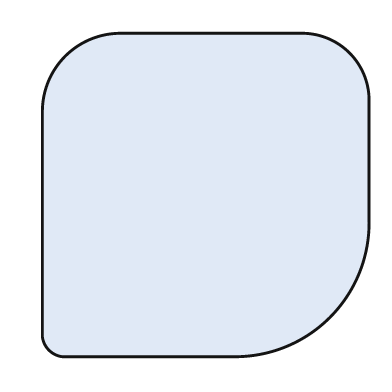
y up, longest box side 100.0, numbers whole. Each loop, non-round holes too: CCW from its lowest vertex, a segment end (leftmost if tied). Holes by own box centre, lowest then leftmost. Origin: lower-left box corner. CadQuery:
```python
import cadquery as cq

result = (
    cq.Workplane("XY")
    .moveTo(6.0, 0.0)
    .lineTo(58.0, 0.0)
    .threePointArc((88.0, 12.0), (100.0, 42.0))
    .lineTo(100.0, 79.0)
    .threePointArc((94.0, 93.0), (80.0, 99.0))
    .lineTo(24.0, 99.0)
    .threePointArc((7.0, 92.0), (0.0, 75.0))
    .lineTo(0.0, 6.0)
    .threePointArc((2.0, 2.0), (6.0, 0.0))
    .close()
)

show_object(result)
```